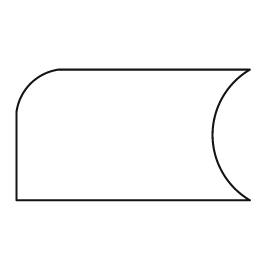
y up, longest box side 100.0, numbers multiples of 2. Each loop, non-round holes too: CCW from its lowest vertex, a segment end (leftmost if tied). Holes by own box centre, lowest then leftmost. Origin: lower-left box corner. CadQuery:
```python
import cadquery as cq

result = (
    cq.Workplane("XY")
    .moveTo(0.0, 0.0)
    .lineTo(100.0, 0.0)
    .threePointArc((84.0, 28.0), (100.0, 56.0))
    .lineTo(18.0, 56.0)
    .threePointArc((6.0, 50.0), (0.0, 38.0))
    .close()
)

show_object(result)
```